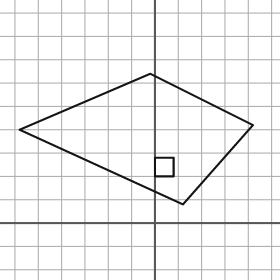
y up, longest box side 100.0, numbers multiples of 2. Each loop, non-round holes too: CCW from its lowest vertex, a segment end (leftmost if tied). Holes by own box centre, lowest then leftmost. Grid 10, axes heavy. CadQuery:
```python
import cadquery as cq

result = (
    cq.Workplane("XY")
    .moveTo(12.0, 8.0)
    .lineTo(42.0, 42.0)
    .lineTo(-2.0, 64.0)
    .lineTo(-58.0, 40.0)
    .close()
    .moveTo(0.0, 20.0)
    .lineTo(8.0, 20.0)
    .lineTo(8.0, 28.0)
    .lineTo(0.0, 28.0)
    .close()
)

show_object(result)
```